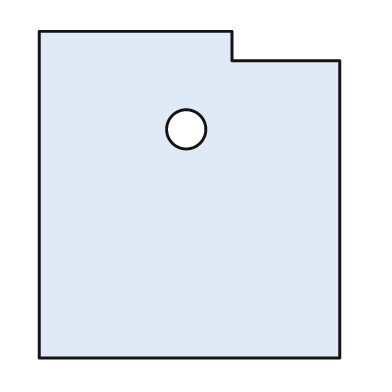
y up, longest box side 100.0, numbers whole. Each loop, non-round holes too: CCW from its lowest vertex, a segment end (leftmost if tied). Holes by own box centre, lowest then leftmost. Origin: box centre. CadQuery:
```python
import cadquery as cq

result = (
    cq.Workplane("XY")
    .moveTo(-46.0, -50.0)
    .lineTo(46.0, -50.0)
    .lineTo(46.0, 41.0)
    .lineTo(13.0, 41.0)
    .lineTo(13.0, 50.0)
    .lineTo(-46.0, 50.0)
    .close()
    .moveTo(-1.0, 20.0)
    .circle(6.0)
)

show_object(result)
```